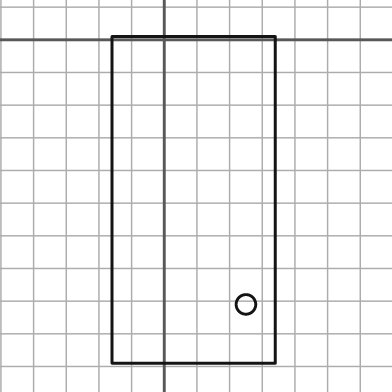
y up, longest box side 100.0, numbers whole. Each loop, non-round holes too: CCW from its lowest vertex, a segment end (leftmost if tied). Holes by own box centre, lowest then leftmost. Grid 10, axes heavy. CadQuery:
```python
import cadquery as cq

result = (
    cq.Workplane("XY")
    .moveTo(-16.0, -99.0)
    .lineTo(34.0, -99.0)
    .lineTo(34.0, 1.0)
    .lineTo(-16.0, 1.0)
    .close()
    .moveTo(25.0, -81.0)
    .circle(3.0)
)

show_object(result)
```